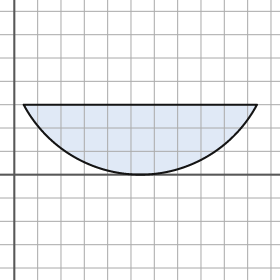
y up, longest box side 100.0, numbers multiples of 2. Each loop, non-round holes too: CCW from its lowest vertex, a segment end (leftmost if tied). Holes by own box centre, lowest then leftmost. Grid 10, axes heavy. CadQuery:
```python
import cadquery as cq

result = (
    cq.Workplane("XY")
    .moveTo(4.0, 30.0)
    .threePointArc((54.0, 0.0), (104.0, 30.0))
    .close()
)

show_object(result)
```